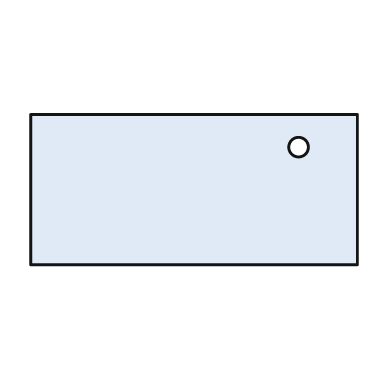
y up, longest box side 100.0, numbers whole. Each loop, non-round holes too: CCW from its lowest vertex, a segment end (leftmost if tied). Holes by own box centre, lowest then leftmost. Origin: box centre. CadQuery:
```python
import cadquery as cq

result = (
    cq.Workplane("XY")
    .moveTo(-50.0, -23.0)
    .lineTo(50.0, -23.0)
    .lineTo(50.0, 23.0)
    .lineTo(-50.0, 23.0)
    .close()
    .moveTo(32.0, 13.0)
    .circle(3.0)
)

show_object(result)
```